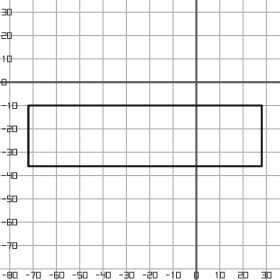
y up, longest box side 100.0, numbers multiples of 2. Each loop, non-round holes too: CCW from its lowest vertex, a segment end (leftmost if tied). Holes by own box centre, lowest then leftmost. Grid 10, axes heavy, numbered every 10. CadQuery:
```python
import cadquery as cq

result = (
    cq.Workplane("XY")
    .moveTo(-72.0, -36.0)
    .lineTo(28.0, -36.0)
    .lineTo(28.0, -10.0)
    .lineTo(-72.0, -10.0)
    .close()
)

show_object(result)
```